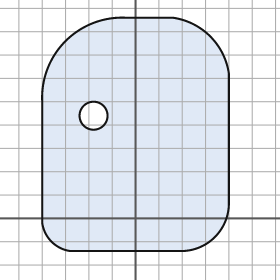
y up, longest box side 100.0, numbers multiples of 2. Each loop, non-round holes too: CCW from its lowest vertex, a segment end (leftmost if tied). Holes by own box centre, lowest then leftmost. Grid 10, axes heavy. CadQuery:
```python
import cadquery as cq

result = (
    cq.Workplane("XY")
    .moveTo(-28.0, -14.0)
    .lineTo(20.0, -14.0)
    .threePointArc((34.0, -8.0), (40.0, 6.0))
    .lineTo(40.0, 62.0)
    .threePointArc((32.0, 78.0), (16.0, 86.0))
    .lineTo(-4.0, 86.0)
    .threePointArc((-30.0, 76.0), (-40.0, 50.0))
    .lineTo(-40.0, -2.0)
    .threePointArc((-36.0, -10.0), (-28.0, -14.0))
    .close()
    .moveTo(-18.0, 44.0)
    .circle(6.0)
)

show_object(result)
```